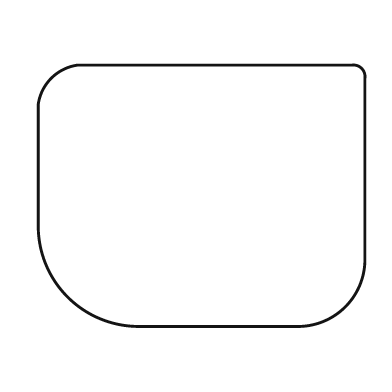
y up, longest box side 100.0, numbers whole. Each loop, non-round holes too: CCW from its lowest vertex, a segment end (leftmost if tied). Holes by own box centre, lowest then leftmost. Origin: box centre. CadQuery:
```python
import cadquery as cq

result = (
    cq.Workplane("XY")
    .moveTo(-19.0, -40.0)
    .lineTo(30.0, -40.0)
    .threePointArc((44.0, -34.0), (50.0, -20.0))
    .lineTo(50.0, 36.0)
    .threePointArc((49.0, 39.0), (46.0, 40.0))
    .lineTo(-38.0, 40.0)
    .threePointArc((-46.0, 36.0), (-50.0, 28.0))
    .lineTo(-50.0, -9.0)
    .threePointArc((-41.0, -31.0), (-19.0, -40.0))
    .close()
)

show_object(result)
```